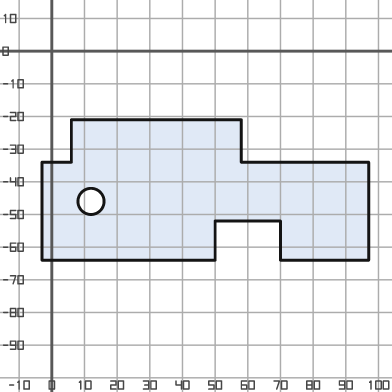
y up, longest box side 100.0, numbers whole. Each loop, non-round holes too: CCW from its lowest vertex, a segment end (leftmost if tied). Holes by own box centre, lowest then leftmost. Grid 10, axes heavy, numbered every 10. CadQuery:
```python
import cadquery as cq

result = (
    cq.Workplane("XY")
    .moveTo(-3.0, -64.0)
    .lineTo(50.0, -64.0)
    .lineTo(50.0, -52.0)
    .lineTo(70.0, -52.0)
    .lineTo(70.0, -64.0)
    .lineTo(97.0, -64.0)
    .lineTo(97.0, -34.0)
    .lineTo(58.0, -34.0)
    .lineTo(58.0, -21.0)
    .lineTo(6.0, -21.0)
    .lineTo(6.0, -34.0)
    .lineTo(-3.0, -34.0)
    .close()
    .moveTo(12.0, -46.0)
    .circle(4.0)
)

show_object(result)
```